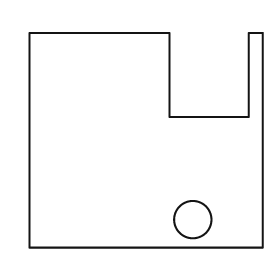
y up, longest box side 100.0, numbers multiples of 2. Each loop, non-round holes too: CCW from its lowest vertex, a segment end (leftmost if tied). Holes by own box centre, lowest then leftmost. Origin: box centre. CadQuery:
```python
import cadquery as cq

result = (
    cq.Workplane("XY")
    .moveTo(-50.0, -46.0)
    .lineTo(50.0, -46.0)
    .lineTo(50.0, 46.0)
    .lineTo(44.0, 46.0)
    .lineTo(44.0, 10.0)
    .lineTo(10.0, 10.0)
    .lineTo(10.0, 46.0)
    .lineTo(-50.0, 46.0)
    .close()
    .moveTo(20.0, -34.0)
    .circle(8.0)
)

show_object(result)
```